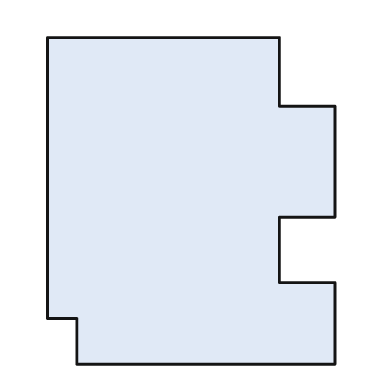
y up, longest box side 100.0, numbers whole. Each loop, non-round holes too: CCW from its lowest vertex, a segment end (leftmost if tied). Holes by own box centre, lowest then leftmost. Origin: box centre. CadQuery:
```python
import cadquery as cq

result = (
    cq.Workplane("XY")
    .moveTo(-35.0, -50.0)
    .lineTo(44.0, -50.0)
    .lineTo(44.0, -25.0)
    .lineTo(27.0, -25.0)
    .lineTo(27.0, -5.0)
    .lineTo(44.0, -5.0)
    .lineTo(44.0, 29.0)
    .lineTo(27.0, 29.0)
    .lineTo(27.0, 50.0)
    .lineTo(-44.0, 50.0)
    .lineTo(-44.0, -36.0)
    .lineTo(-35.0, -36.0)
    .close()
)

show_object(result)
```